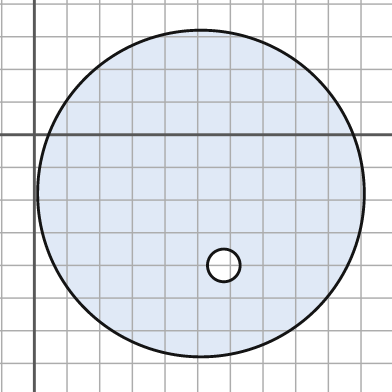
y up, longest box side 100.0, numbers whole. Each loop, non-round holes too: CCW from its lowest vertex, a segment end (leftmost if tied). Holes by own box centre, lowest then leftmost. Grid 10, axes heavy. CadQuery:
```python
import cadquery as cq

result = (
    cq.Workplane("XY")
    .moveTo(51.0, -18.0)
    .circle(50.0)
    .moveTo(58.0, -40.0)
    .circle(5.0)
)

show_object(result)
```